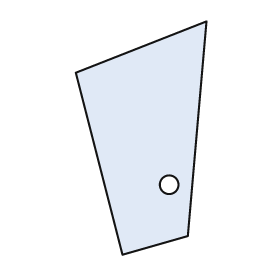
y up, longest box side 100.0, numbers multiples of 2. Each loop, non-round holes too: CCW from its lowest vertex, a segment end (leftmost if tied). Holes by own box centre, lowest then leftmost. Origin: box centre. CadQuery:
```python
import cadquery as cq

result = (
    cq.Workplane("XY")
    .moveTo(-8.0, -50.0)
    .lineTo(20.0, -42.0)
    .lineTo(28.0, 50.0)
    .lineTo(-28.0, 28.0)
    .close()
    .moveTo(12.0, -20.0)
    .circle(4.0)
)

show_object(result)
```